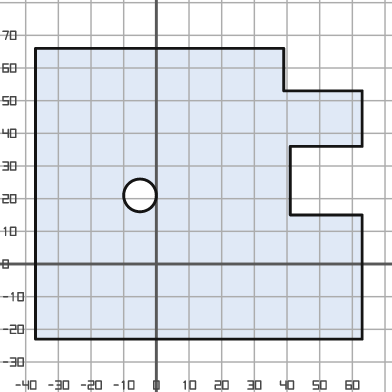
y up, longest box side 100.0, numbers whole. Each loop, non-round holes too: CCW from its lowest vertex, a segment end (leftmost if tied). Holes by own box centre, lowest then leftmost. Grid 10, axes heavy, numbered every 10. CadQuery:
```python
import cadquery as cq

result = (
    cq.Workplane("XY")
    .moveTo(-37.0, -23.0)
    .lineTo(63.0, -23.0)
    .lineTo(63.0, 15.0)
    .lineTo(41.0, 15.0)
    .lineTo(41.0, 36.0)
    .lineTo(63.0, 36.0)
    .lineTo(63.0, 53.0)
    .lineTo(39.0, 53.0)
    .lineTo(39.0, 66.0)
    .lineTo(-37.0, 66.0)
    .close()
    .moveTo(-5.0, 21.0)
    .circle(5.0)
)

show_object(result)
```